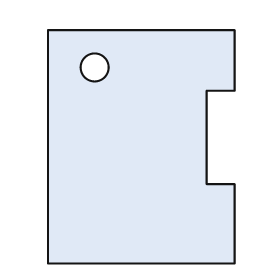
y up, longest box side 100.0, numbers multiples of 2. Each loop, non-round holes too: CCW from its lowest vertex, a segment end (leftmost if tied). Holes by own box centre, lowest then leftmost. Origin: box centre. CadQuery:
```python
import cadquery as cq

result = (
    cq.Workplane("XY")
    .moveTo(-40.0, -50.0)
    .lineTo(40.0, -50.0)
    .lineTo(40.0, -16.0)
    .lineTo(28.0, -16.0)
    .lineTo(28.0, 24.0)
    .lineTo(40.0, 24.0)
    .lineTo(40.0, 50.0)
    .lineTo(-40.0, 50.0)
    .close()
    .moveTo(-20.0, 34.0)
    .circle(6.0)
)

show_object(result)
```